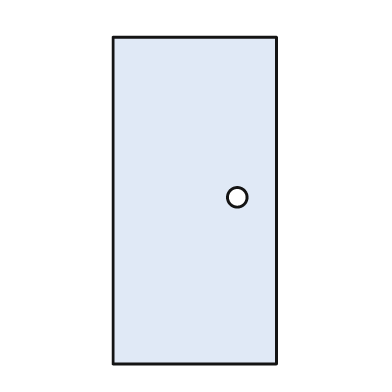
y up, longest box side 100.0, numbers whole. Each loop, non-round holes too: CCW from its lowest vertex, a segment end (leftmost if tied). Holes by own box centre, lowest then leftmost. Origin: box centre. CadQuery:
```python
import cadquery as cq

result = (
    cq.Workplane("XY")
    .moveTo(-25.0, -50.0)
    .lineTo(25.0, -50.0)
    .lineTo(25.0, 50.0)
    .lineTo(-25.0, 50.0)
    .close()
    .moveTo(13.0, 1.0)
    .circle(3.0)
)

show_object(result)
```